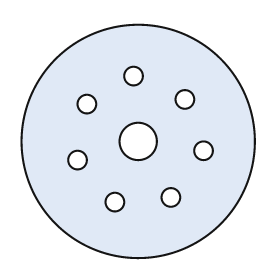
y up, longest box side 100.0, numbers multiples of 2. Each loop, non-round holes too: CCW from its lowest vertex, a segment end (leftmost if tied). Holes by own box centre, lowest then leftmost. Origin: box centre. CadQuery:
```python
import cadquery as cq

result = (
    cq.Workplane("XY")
    .moveTo(0.0, 0.0)
    .circle(50.0)
    .moveTo(-10.0, -26.0)
    .circle(4.0)
    .moveTo(14.0, -24.0)
    .circle(4.0)
    .moveTo(-26.0, -8.0)
    .circle(4.0)
    .moveTo(28.0, -4.0)
    .circle(4.0)
    .moveTo(0.0, 0.0)
    .circle(8.0)
    .moveTo(-22.0, 16.0)
    .circle(4.0)
    .moveTo(20.0, 18.0)
    .circle(4.0)
    .moveTo(-2.0, 28.0)
    .circle(4.0)
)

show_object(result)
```